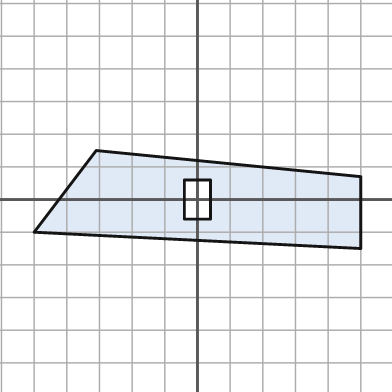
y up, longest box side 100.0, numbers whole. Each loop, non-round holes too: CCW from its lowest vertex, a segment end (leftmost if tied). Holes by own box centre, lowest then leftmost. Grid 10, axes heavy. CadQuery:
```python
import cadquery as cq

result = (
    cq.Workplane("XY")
    .moveTo(50.0, -15.0)
    .lineTo(50.0, 7.0)
    .lineTo(-31.0, 15.0)
    .lineTo(-50.0, -10.0)
    .close()
    .moveTo(-4.0, -6.0)
    .lineTo(4.0, -6.0)
    .lineTo(4.0, 6.0)
    .lineTo(-4.0, 6.0)
    .close()
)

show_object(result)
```